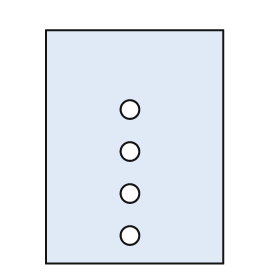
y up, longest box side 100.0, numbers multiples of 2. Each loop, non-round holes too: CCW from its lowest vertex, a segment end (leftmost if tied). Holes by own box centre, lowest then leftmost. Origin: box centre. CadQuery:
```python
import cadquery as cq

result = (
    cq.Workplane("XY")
    .moveTo(-38.0, -50.0)
    .lineTo(38.0, -50.0)
    .lineTo(38.0, 50.0)
    .lineTo(-38.0, 50.0)
    .close()
    .moveTo(-2.0, -38.0)
    .circle(4.0)
    .moveTo(-2.0, -20.0)
    .circle(4.0)
    .moveTo(-2.0, -2.0)
    .circle(4.0)
    .moveTo(-2.0, 16.0)
    .circle(4.0)
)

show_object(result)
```